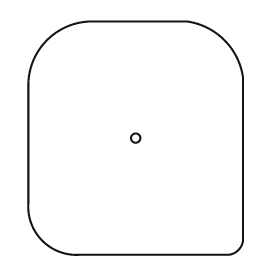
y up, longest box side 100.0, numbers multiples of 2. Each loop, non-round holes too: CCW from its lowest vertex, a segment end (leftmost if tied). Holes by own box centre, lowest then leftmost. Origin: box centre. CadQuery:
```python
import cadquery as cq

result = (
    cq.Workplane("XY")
    .moveTo(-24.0, -50.0)
    .lineTo(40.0, -50.0)
    .threePointArc((44.0, -48.0), (46.0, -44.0))
    .lineTo(46.0, 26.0)
    .threePointArc((38.0, 42.0), (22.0, 50.0))
    .lineTo(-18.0, 50.0)
    .threePointArc((-38.0, 42.0), (-46.0, 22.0))
    .lineTo(-46.0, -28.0)
    .threePointArc((-40.0, -44.0), (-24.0, -50.0))
    .close()
    .moveTo(0.0, 0.0)
    .circle(2.0)
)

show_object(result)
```